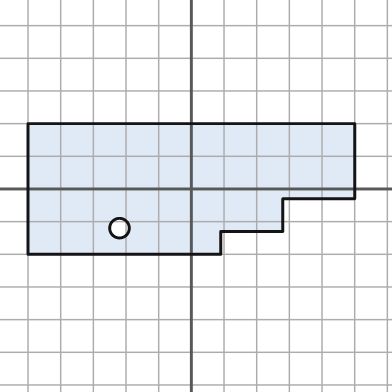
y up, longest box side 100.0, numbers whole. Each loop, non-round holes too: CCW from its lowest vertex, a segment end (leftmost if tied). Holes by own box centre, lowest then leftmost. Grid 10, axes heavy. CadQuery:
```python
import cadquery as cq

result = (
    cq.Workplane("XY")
    .moveTo(-50.0, -20.0)
    .lineTo(9.0, -20.0)
    .lineTo(9.0, -13.0)
    .lineTo(28.0, -13.0)
    .lineTo(28.0, -3.0)
    .lineTo(50.0, -3.0)
    .lineTo(50.0, 20.0)
    .lineTo(-50.0, 20.0)
    .close()
    .moveTo(-22.0, -12.0)
    .circle(3.0)
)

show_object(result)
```